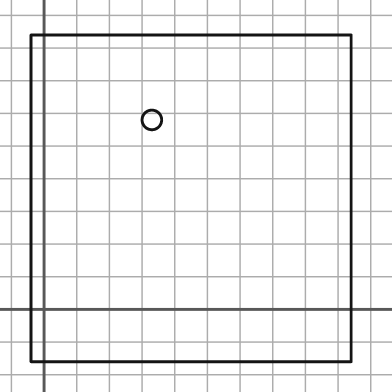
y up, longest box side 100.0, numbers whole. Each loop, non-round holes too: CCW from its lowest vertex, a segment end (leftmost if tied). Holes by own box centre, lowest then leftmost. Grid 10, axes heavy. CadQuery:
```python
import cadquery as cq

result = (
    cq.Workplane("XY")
    .moveTo(-4.0, -16.0)
    .lineTo(94.0, -16.0)
    .lineTo(94.0, 84.0)
    .lineTo(-4.0, 84.0)
    .close()
    .moveTo(33.0, 58.0)
    .circle(3.0)
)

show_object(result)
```